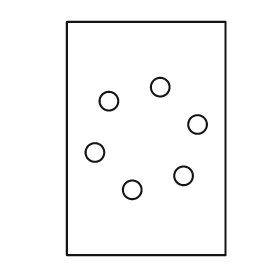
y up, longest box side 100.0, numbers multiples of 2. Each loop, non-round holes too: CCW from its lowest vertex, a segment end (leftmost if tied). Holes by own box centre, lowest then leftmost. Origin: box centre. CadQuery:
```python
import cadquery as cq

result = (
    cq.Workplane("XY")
    .moveTo(-34.0, -50.0)
    .lineTo(34.0, -50.0)
    .lineTo(34.0, 50.0)
    .lineTo(-34.0, 50.0)
    .close()
    .moveTo(-6.0, -22.0)
    .circle(4.0)
    .moveTo(16.0, -16.0)
    .circle(4.0)
    .moveTo(-22.0, -6.0)
    .circle(4.0)
    .moveTo(22.0, 6.0)
    .circle(4.0)
    .moveTo(-16.0, 16.0)
    .circle(4.0)
    .moveTo(6.0, 22.0)
    .circle(4.0)
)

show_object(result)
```